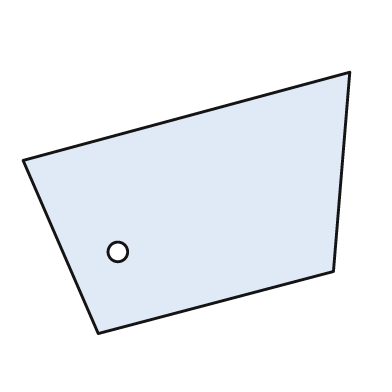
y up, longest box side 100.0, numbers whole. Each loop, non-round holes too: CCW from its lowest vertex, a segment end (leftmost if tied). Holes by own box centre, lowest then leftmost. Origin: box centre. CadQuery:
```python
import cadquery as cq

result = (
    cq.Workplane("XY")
    .moveTo(-27.0, -40.0)
    .lineTo(45.0, -21.0)
    .lineTo(50.0, 40.0)
    .lineTo(-50.0, 13.0)
    .close()
    .moveTo(-21.0, -15.0)
    .circle(3.0)
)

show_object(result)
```